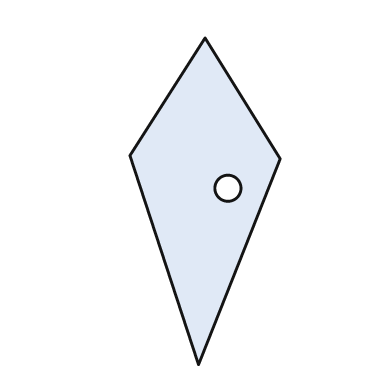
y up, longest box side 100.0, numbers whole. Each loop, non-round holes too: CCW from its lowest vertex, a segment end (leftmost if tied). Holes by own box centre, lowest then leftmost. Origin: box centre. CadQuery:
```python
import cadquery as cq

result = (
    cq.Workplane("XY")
    .moveTo(-2.0, -50.0)
    .lineTo(23.0, 13.0)
    .lineTo(0.0, 50.0)
    .lineTo(-23.0, 14.0)
    .close()
    .moveTo(7.0, 4.0)
    .circle(4.0)
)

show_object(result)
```